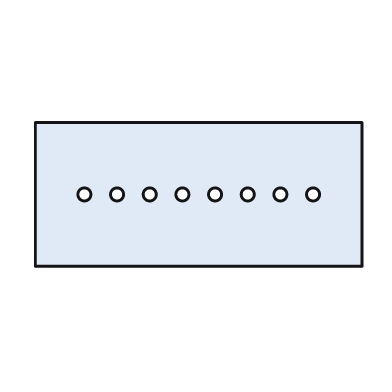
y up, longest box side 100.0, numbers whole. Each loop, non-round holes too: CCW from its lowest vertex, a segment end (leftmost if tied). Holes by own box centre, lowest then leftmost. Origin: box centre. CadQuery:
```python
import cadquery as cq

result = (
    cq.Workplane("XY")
    .moveTo(-50.0, -22.0)
    .lineTo(50.0, -22.0)
    .lineTo(50.0, 22.0)
    .lineTo(-50.0, 22.0)
    .close()
    .moveTo(-35.0, 0.0)
    .circle(2.0)
    .moveTo(-25.0, 0.0)
    .circle(2.0)
    .moveTo(-15.0, 0.0)
    .circle(2.0)
    .moveTo(-5.0, 0.0)
    .circle(2.0)
    .moveTo(5.0, 0.0)
    .circle(2.0)
    .moveTo(15.0, 0.0)
    .circle(2.0)
    .moveTo(25.0, 0.0)
    .circle(2.0)
    .moveTo(35.0, 0.0)
    .circle(2.0)
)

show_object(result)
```